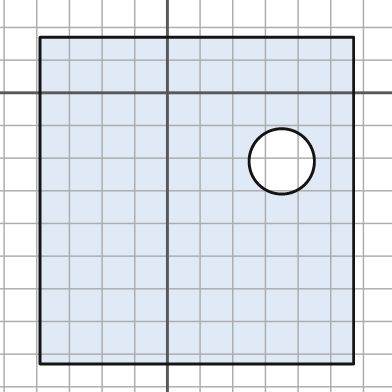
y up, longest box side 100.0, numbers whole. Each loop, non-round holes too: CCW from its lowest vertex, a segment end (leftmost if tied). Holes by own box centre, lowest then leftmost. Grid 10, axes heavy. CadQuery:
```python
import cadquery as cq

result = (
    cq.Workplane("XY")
    .moveTo(-39.0, -83.0)
    .lineTo(57.0, -83.0)
    .lineTo(57.0, 17.0)
    .lineTo(-39.0, 17.0)
    .close()
    .moveTo(35.0, -21.0)
    .circle(10.0)
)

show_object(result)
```